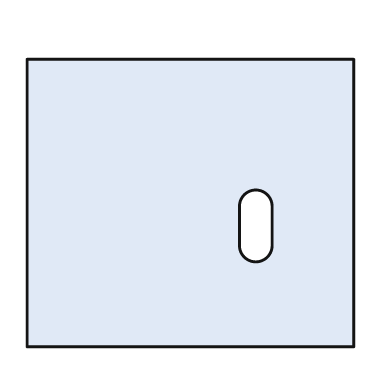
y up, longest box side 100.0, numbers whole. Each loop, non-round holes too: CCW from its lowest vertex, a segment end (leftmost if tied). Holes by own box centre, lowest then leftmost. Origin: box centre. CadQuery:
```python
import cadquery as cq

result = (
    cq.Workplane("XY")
    .moveTo(-50.0, -44.0)
    .lineTo(50.0, -44.0)
    .lineTo(50.0, 44.0)
    .lineTo(-50.0, 44.0)
    .close()
    .moveTo(15.0, -13.0)
    .threePointArc((20.0, -18.0), (25.0, -13.0))
    .lineTo(25.0, -1.0)
    .threePointArc((20.0, 4.0), (15.0, -1.0))
    .close()
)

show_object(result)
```